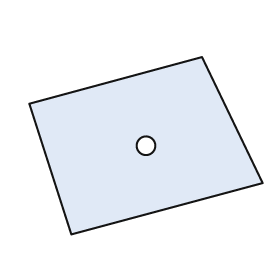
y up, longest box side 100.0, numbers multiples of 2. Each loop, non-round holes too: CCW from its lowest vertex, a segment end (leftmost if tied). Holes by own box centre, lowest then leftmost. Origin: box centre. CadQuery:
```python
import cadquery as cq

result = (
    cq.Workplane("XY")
    .moveTo(-32.0, -38.0)
    .lineTo(50.0, -16.0)
    .lineTo(24.0, 38.0)
    .lineTo(-50.0, 18.0)
    .close()
    .moveTo(0.0, 0.0)
    .circle(4.0)
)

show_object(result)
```